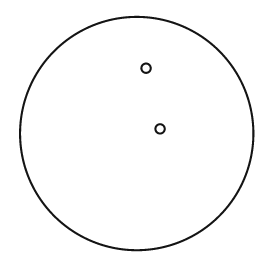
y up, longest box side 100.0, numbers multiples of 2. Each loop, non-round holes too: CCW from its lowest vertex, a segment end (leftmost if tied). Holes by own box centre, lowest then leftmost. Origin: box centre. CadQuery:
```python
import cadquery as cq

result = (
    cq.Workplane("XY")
    .moveTo(0.0, 0.0)
    .circle(50.0)
    .moveTo(10.0, 2.0)
    .circle(2.0)
    .moveTo(4.0, 28.0)
    .circle(2.0)
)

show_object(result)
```